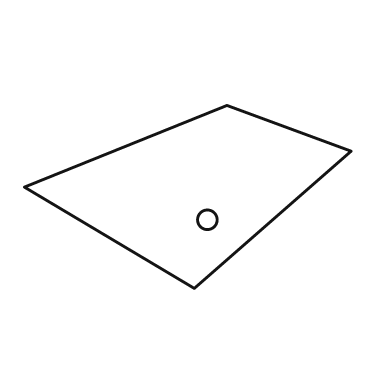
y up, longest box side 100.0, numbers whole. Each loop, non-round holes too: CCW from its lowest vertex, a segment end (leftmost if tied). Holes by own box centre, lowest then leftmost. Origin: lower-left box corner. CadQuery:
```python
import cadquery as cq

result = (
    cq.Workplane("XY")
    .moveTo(52.0, 0.0)
    .lineTo(100.0, 42.0)
    .lineTo(62.0, 56.0)
    .lineTo(0.0, 31.0)
    .close()
    .moveTo(56.0, 21.0)
    .circle(3.0)
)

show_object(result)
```